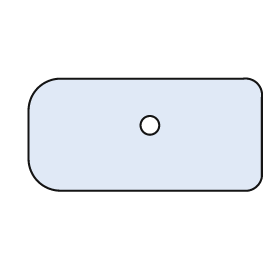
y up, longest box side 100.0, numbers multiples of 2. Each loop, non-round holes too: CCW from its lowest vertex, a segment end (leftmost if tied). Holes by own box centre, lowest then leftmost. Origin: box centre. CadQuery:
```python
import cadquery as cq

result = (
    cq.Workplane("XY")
    .moveTo(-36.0, -24.0)
    .lineTo(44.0, -24.0)
    .threePointArc((48.0, -22.0), (50.0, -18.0))
    .lineTo(50.0, 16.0)
    .threePointArc((48.0, 22.0), (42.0, 24.0))
    .lineTo(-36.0, 24.0)
    .threePointArc((-46.0, 20.0), (-50.0, 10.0))
    .lineTo(-50.0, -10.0)
    .threePointArc((-46.0, -20.0), (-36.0, -24.0))
    .close()
    .moveTo(2.0, 4.0)
    .circle(4.0)
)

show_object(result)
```